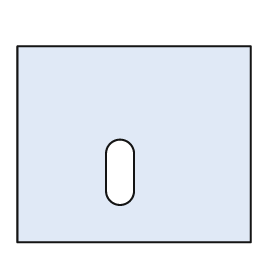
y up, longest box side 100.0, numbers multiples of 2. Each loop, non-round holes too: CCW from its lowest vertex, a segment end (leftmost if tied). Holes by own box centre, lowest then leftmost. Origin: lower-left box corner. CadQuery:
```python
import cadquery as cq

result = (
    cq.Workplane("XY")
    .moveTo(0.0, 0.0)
    .lineTo(100.0, 0.0)
    .lineTo(100.0, 84.0)
    .lineTo(0.0, 84.0)
    .close()
    .moveTo(38.0, 22.0)
    .threePointArc((44.0, 16.0), (50.0, 22.0))
    .lineTo(50.0, 38.0)
    .threePointArc((44.0, 44.0), (38.0, 38.0))
    .close()
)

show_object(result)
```